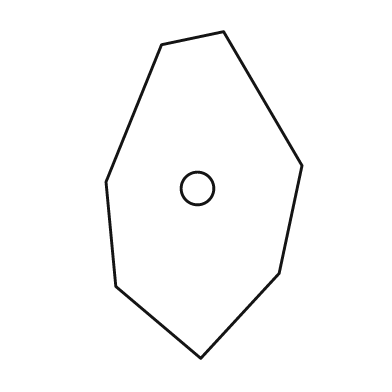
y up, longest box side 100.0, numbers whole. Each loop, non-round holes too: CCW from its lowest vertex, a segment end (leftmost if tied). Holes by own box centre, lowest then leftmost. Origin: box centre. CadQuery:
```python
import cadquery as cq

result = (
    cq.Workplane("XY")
    .moveTo(-1.0, -50.0)
    .lineTo(23.0, -24.0)
    .lineTo(30.0, 9.0)
    .lineTo(6.0, 50.0)
    .lineTo(-13.0, 46.0)
    .lineTo(-30.0, 4.0)
    .lineTo(-27.0, -28.0)
    .close()
    .moveTo(-2.0, 2.0)
    .circle(5.0)
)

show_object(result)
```